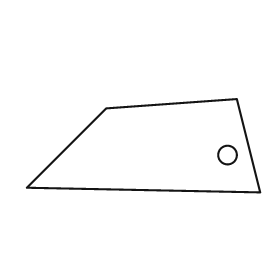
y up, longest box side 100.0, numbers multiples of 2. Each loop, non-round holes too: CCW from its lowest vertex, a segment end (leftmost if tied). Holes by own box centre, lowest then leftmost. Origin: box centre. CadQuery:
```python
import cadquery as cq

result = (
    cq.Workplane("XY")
    .moveTo(50.0, -20.0)
    .lineTo(40.0, 20.0)
    .lineTo(-16.0, 16.0)
    .lineTo(-50.0, -18.0)
    .close()
    .moveTo(36.0, -4.0)
    .circle(4.0)
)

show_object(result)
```